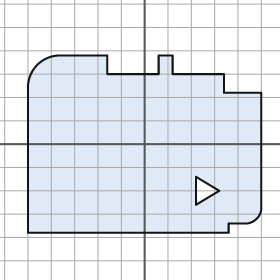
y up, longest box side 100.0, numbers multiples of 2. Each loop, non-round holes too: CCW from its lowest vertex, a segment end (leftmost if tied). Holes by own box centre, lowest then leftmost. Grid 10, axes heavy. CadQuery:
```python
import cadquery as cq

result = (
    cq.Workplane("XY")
    .moveTo(-50.0, -38.0)
    .lineTo(36.0, -38.0)
    .lineTo(36.0, -34.0)
    .lineTo(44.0, -34.0)
    .threePointArc((48.0, -32.0), (50.0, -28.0))
    .lineTo(50.0, 22.0)
    .lineTo(34.0, 22.0)
    .lineTo(34.0, 30.0)
    .lineTo(12.0, 30.0)
    .lineTo(12.0, 38.0)
    .lineTo(6.0, 38.0)
    .lineTo(6.0, 30.0)
    .lineTo(-16.0, 30.0)
    .lineTo(-16.0, 38.0)
    .lineTo(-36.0, 38.0)
    .threePointArc((-46.0, 34.0), (-50.0, 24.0))
    .close()
    .moveTo(22.0, -26.0)
    .lineTo(32.0, -20.0)
    .lineTo(22.0, -14.0)
    .close()
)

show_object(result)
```